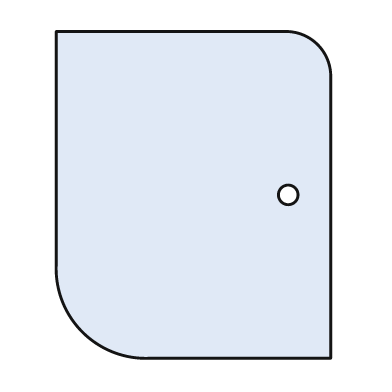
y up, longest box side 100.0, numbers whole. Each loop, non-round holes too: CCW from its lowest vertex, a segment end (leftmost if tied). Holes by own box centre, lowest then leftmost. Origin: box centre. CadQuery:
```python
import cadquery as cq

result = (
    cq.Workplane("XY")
    .moveTo(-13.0, -50.0)
    .lineTo(42.0, -50.0)
    .lineTo(42.0, 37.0)
    .threePointArc((38.0, 46.0), (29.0, 50.0))
    .lineTo(-42.0, 50.0)
    .lineTo(-42.0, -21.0)
    .threePointArc((-34.0, -42.0), (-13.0, -50.0))
    .close()
    .moveTo(29.0, 0.0)
    .circle(3.0)
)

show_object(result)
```